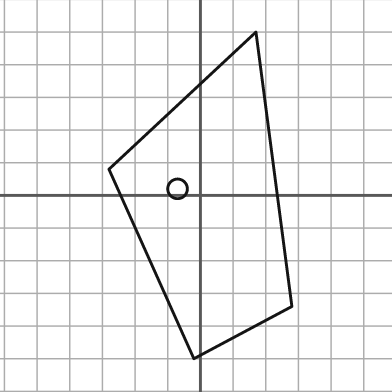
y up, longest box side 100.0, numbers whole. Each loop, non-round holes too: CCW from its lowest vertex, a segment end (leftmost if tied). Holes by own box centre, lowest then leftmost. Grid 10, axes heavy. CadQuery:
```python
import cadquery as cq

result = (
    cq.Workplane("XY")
    .moveTo(-2.0, -50.0)
    .lineTo(28.0, -34.0)
    .lineTo(17.0, 50.0)
    .lineTo(-28.0, 8.0)
    .close()
    .moveTo(-7.0, 2.0)
    .circle(3.0)
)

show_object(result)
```